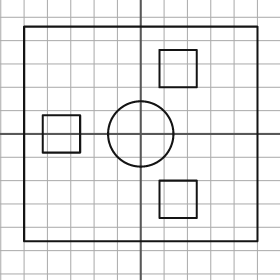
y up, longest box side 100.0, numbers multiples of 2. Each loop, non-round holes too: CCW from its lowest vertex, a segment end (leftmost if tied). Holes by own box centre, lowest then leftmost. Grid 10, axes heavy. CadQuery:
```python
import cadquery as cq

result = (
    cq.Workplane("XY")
    .moveTo(-50.0, -46.0)
    .lineTo(50.0, -46.0)
    .lineTo(50.0, 46.0)
    .lineTo(-50.0, 46.0)
    .close()
    .moveTo(8.0, -36.0)
    .lineTo(24.0, -36.0)
    .lineTo(24.0, -20.0)
    .lineTo(8.0, -20.0)
    .close()
    .moveTo(-42.0, -8.0)
    .lineTo(-26.0, -8.0)
    .lineTo(-26.0, 8.0)
    .lineTo(-42.0, 8.0)
    .close()
    .moveTo(0.0, 0.0)
    .circle(14.0)
    .moveTo(8.0, 20.0)
    .lineTo(24.0, 20.0)
    .lineTo(24.0, 36.0)
    .lineTo(8.0, 36.0)
    .close()
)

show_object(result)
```